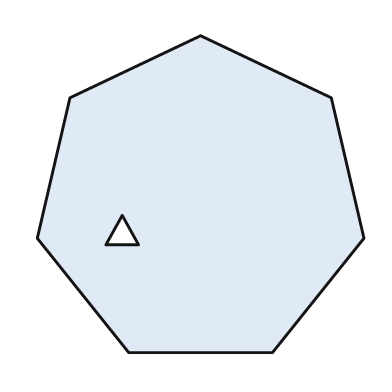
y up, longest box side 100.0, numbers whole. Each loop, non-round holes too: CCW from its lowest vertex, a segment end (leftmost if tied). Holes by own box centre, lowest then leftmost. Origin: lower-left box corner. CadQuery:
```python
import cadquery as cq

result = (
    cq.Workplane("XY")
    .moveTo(28.0, 0.0)
    .lineTo(72.0, 0.0)
    .lineTo(100.0, 35.0)
    .lineTo(90.0, 78.0)
    .lineTo(50.0, 97.0)
    .lineTo(10.0, 78.0)
    .lineTo(0.0, 35.0)
    .close()
    .moveTo(21.0, 33.0)
    .lineTo(31.0, 33.0)
    .lineTo(26.0, 42.0)
    .close()
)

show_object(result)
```